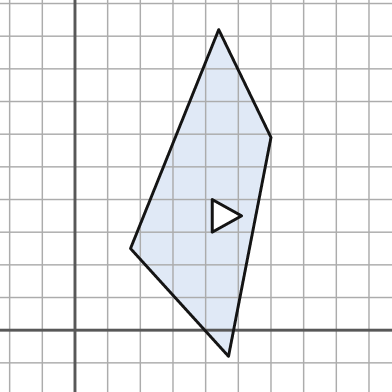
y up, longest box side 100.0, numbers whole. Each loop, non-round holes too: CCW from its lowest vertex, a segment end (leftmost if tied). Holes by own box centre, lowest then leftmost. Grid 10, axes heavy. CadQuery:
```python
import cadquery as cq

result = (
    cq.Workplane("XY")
    .moveTo(47.0, -8.0)
    .lineTo(60.0, 59.0)
    .lineTo(44.0, 92.0)
    .lineTo(17.0, 25.0)
    .close()
    .moveTo(42.0, 30.0)
    .lineTo(51.0, 35.0)
    .lineTo(42.0, 40.0)
    .close()
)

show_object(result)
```